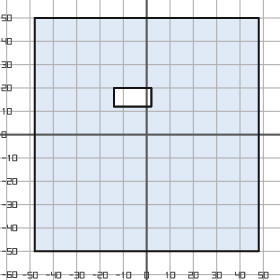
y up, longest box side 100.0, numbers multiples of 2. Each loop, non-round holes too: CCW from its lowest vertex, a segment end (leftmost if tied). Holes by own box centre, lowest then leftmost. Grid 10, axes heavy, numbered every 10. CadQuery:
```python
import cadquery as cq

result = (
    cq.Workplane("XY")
    .moveTo(-48.0, -50.0)
    .lineTo(48.0, -50.0)
    .lineTo(48.0, 50.0)
    .lineTo(-48.0, 50.0)
    .close()
    .moveTo(-14.0, 12.0)
    .lineTo(2.0, 12.0)
    .lineTo(2.0, 20.0)
    .lineTo(-14.0, 20.0)
    .close()
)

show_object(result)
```